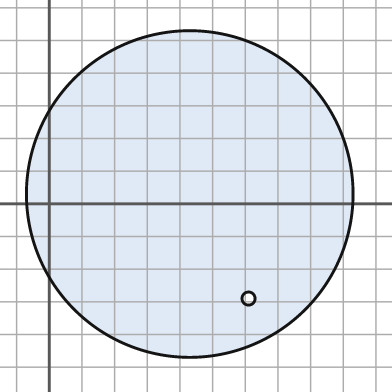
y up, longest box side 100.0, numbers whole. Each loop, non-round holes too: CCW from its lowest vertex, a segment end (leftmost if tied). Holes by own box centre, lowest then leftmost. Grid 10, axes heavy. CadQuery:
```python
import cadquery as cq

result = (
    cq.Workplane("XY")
    .moveTo(43.0, 3.0)
    .circle(50.0)
    .moveTo(61.0, -29.0)
    .circle(2.0)
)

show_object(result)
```